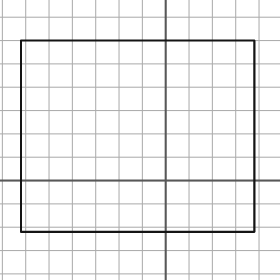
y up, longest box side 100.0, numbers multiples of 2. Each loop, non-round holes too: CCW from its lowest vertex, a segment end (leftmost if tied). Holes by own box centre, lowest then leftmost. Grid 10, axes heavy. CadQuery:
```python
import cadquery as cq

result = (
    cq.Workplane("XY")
    .moveTo(-62.0, -22.0)
    .lineTo(38.0, -22.0)
    .lineTo(38.0, 60.0)
    .lineTo(-62.0, 60.0)
    .close()
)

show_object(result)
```